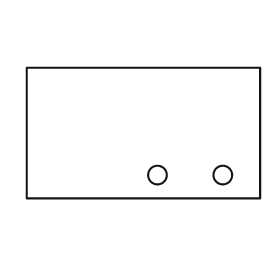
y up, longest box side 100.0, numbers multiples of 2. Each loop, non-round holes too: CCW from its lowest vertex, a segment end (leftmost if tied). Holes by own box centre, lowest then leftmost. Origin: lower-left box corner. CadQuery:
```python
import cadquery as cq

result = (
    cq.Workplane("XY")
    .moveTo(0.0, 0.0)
    .lineTo(100.0, 0.0)
    .lineTo(100.0, 56.0)
    .lineTo(0.0, 56.0)
    .close()
    .moveTo(56.0, 10.0)
    .circle(4.0)
    .moveTo(84.0, 10.0)
    .circle(4.0)
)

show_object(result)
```